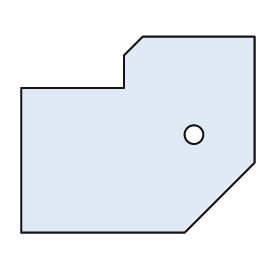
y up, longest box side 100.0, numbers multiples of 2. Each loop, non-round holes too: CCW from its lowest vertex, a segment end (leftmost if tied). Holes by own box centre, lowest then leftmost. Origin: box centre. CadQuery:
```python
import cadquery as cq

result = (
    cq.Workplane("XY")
    .moveTo(-50.0, -42.0)
    .lineTo(20.0, -42.0)
    .lineTo(50.0, -12.0)
    .lineTo(50.0, 42.0)
    .lineTo(2.0, 42.0)
    .lineTo(-6.0, 34.0)
    .lineTo(-6.0, 20.0)
    .lineTo(-50.0, 20.0)
    .close()
    .moveTo(24.0, 0.0)
    .circle(4.0)
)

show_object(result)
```